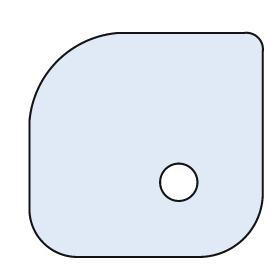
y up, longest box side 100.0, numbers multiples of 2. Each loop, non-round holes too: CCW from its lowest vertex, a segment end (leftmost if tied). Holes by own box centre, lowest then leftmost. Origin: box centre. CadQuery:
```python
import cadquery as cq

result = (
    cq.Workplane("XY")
    .moveTo(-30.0, -48.0)
    .lineTo(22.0, -48.0)
    .threePointArc((42.0, -40.0), (50.0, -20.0))
    .lineTo(50.0, 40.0)
    .threePointArc((48.0, 46.0), (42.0, 48.0))
    .lineTo(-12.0, 48.0)
    .threePointArc((-38.0, 36.0), (-50.0, 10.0))
    .lineTo(-50.0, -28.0)
    .threePointArc((-44.0, -42.0), (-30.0, -48.0))
    .close()
    .moveTo(14.0, -16.0)
    .circle(8.0)
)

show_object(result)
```